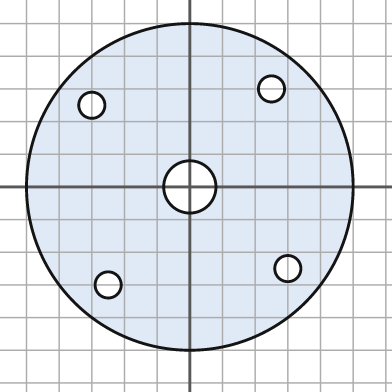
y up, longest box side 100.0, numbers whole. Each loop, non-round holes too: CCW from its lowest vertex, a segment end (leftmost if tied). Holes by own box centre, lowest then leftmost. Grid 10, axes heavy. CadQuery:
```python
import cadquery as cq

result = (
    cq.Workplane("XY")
    .moveTo(0.0, 0.0)
    .circle(50.0)
    .moveTo(-25.0, -30.0)
    .circle(4.0)
    .moveTo(30.0, -25.0)
    .circle(4.0)
    .moveTo(0.0, 0.0)
    .circle(8.0)
    .moveTo(-30.0, 25.0)
    .circle(4.0)
    .moveTo(25.0, 30.0)
    .circle(4.0)
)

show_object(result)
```